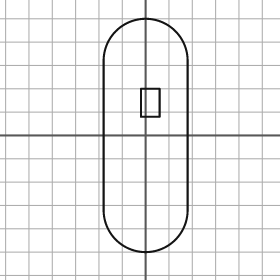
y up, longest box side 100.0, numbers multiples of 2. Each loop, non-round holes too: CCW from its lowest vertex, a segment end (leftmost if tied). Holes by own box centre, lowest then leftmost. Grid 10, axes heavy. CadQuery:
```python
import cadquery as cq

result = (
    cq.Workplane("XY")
    .moveTo(-18.0, -32.0)
    .threePointArc((0.0, -50.0), (18.0, -32.0))
    .lineTo(18.0, 32.0)
    .threePointArc((0.0, 50.0), (-18.0, 32.0))
    .close()
    .moveTo(-2.0, 8.0)
    .lineTo(6.0, 8.0)
    .lineTo(6.0, 20.0)
    .lineTo(-2.0, 20.0)
    .close()
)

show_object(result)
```